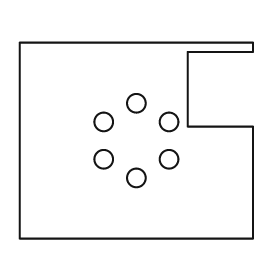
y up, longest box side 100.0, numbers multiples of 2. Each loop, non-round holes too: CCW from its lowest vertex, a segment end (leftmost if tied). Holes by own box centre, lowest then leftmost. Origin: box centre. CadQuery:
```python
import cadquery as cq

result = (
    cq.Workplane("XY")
    .moveTo(-50.0, -42.0)
    .lineTo(50.0, -42.0)
    .lineTo(50.0, 6.0)
    .lineTo(22.0, 6.0)
    .lineTo(22.0, 38.0)
    .lineTo(50.0, 38.0)
    .lineTo(50.0, 42.0)
    .lineTo(-50.0, 42.0)
    .close()
    .moveTo(0.0, -16.0)
    .circle(4.0)
    .moveTo(-14.0, -8.0)
    .circle(4.0)
    .moveTo(14.0, -8.0)
    .circle(4.0)
    .moveTo(-14.0, 8.0)
    .circle(4.0)
    .moveTo(14.0, 8.0)
    .circle(4.0)
    .moveTo(0.0, 16.0)
    .circle(4.0)
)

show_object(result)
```